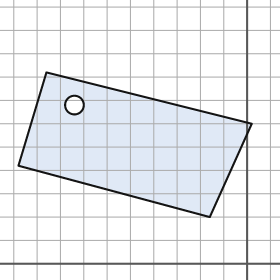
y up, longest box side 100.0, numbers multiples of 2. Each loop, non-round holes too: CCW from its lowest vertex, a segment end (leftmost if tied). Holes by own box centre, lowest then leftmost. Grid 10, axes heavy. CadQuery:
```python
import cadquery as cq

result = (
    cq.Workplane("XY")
    .moveTo(-16.0, 20.0)
    .lineTo(2.0, 60.0)
    .lineTo(-86.0, 82.0)
    .lineTo(-98.0, 42.0)
    .close()
    .moveTo(-74.0, 68.0)
    .circle(4.0)
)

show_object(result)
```